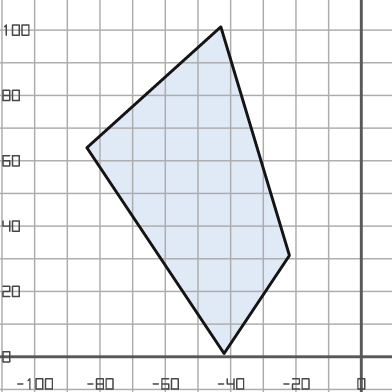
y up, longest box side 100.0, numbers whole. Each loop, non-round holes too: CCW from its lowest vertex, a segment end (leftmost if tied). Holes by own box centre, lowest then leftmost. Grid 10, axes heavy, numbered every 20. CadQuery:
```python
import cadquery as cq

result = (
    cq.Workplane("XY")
    .moveTo(-42.0, 1.0)
    .lineTo(-22.0, 31.0)
    .lineTo(-43.0, 101.0)
    .lineTo(-84.0, 64.0)
    .close()
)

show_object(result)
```